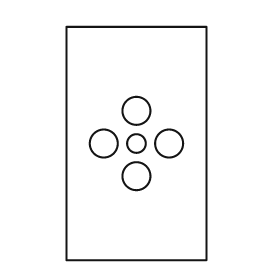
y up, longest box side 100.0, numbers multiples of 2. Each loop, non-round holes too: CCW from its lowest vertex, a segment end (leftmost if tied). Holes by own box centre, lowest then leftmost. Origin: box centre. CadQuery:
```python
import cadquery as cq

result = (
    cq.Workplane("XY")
    .moveTo(-30.0, -50.0)
    .lineTo(30.0, -50.0)
    .lineTo(30.0, 50.0)
    .lineTo(-30.0, 50.0)
    .close()
    .moveTo(0.0, -14.0)
    .circle(6.0)
    .moveTo(-14.0, 0.0)
    .circle(6.0)
    .moveTo(0.0, 0.0)
    .circle(4.0)
    .moveTo(14.0, 0.0)
    .circle(6.0)
    .moveTo(0.0, 14.0)
    .circle(6.0)
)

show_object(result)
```